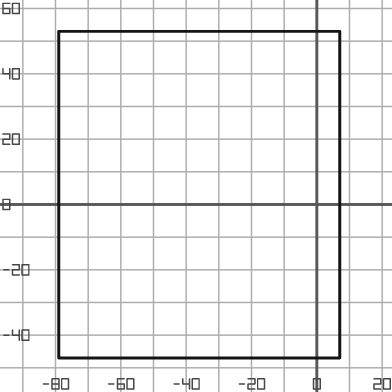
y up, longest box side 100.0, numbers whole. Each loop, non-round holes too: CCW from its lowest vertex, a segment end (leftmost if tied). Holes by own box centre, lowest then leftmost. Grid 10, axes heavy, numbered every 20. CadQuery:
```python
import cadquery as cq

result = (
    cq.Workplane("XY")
    .moveTo(-79.0, -47.0)
    .lineTo(7.0, -47.0)
    .lineTo(7.0, 53.0)
    .lineTo(-79.0, 53.0)
    .close()
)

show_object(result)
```